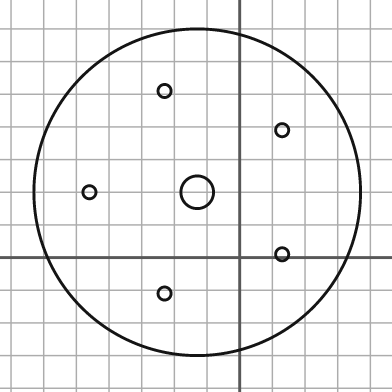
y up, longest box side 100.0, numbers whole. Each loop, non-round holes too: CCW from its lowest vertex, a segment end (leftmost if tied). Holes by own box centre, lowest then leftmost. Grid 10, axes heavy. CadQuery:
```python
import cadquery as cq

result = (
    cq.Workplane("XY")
    .moveTo(-13.0, 20.0)
    .circle(50.0)
    .moveTo(-23.0, -11.0)
    .circle(2.0)
    .moveTo(13.0, 1.0)
    .circle(2.0)
    .moveTo(-46.0, 20.0)
    .circle(2.0)
    .moveTo(-13.0, 20.0)
    .circle(5.0)
    .moveTo(13.0, 39.0)
    .circle(2.0)
    .moveTo(-23.0, 51.0)
    .circle(2.0)
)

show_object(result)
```